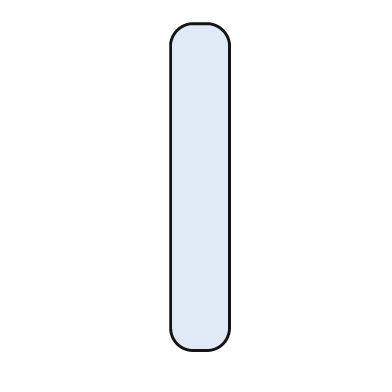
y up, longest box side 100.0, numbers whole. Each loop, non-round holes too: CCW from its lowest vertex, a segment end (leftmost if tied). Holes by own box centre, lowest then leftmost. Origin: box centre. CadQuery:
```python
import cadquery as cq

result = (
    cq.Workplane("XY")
    .moveTo(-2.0, -50.0)
    .lineTo(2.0, -50.0)
    .threePointArc((7.0, -48.0), (9.0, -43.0))
    .lineTo(9.0, 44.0)
    .threePointArc((7.0, 48.0), (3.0, 50.0))
    .lineTo(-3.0, 50.0)
    .threePointArc((-7.0, 48.0), (-9.0, 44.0))
    .lineTo(-9.0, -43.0)
    .threePointArc((-7.0, -48.0), (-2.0, -50.0))
    .close()
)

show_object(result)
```